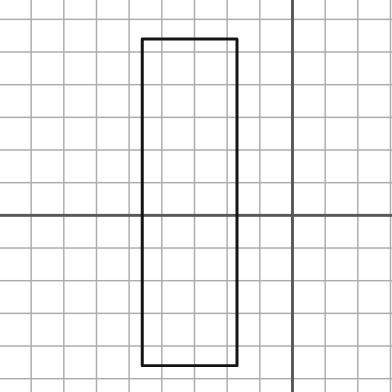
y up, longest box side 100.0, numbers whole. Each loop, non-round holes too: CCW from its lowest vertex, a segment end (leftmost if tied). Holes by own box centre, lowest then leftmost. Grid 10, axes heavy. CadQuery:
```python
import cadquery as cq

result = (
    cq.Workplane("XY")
    .moveTo(-46.0, -46.0)
    .lineTo(-17.0, -46.0)
    .lineTo(-17.0, 54.0)
    .lineTo(-46.0, 54.0)
    .close()
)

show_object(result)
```